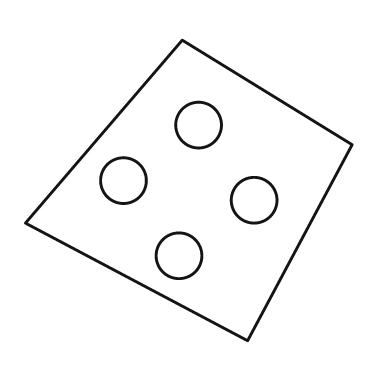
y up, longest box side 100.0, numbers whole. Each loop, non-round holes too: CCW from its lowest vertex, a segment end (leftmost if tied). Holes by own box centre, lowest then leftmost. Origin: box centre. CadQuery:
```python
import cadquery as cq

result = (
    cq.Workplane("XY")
    .moveTo(18.0, -46.0)
    .lineTo(50.0, 14.0)
    .lineTo(-2.0, 46.0)
    .lineTo(-50.0, -10.0)
    .close()
    .moveTo(-3.0, -20.0)
    .circle(7.0)
    .moveTo(20.0, -3.0)
    .circle(7.0)
    .moveTo(-20.0, 3.0)
    .circle(7.0)
    .moveTo(3.0, 20.0)
    .circle(7.0)
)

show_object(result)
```